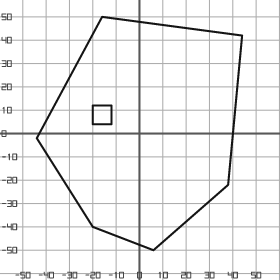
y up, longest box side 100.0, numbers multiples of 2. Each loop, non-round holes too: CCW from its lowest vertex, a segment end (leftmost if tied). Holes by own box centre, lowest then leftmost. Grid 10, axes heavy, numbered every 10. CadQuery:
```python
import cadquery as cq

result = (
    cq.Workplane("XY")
    .moveTo(6.0, -50.0)
    .lineTo(38.0, -22.0)
    .lineTo(44.0, 42.0)
    .lineTo(-16.0, 50.0)
    .lineTo(-44.0, -2.0)
    .lineTo(-20.0, -40.0)
    .close()
    .moveTo(-20.0, 4.0)
    .lineTo(-12.0, 4.0)
    .lineTo(-12.0, 12.0)
    .lineTo(-20.0, 12.0)
    .close()
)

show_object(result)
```